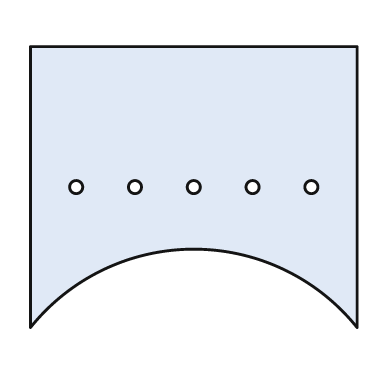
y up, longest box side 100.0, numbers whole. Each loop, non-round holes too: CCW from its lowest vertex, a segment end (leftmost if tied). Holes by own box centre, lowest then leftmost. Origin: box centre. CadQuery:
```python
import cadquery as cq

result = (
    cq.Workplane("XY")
    .moveTo(-50.0, -43.0)
    .threePointArc((0.0, -19.0), (50.0, -43.0))
    .lineTo(50.0, 43.0)
    .lineTo(-50.0, 43.0)
    .close()
    .moveTo(-36.0, 0.0)
    .circle(2.0)
    .moveTo(-18.0, 0.0)
    .circle(2.0)
    .moveTo(0.0, 0.0)
    .circle(2.0)
    .moveTo(18.0, 0.0)
    .circle(2.0)
    .moveTo(36.0, 0.0)
    .circle(2.0)
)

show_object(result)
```